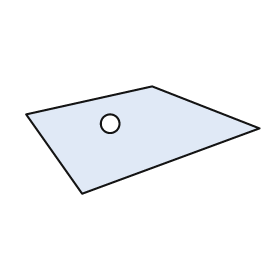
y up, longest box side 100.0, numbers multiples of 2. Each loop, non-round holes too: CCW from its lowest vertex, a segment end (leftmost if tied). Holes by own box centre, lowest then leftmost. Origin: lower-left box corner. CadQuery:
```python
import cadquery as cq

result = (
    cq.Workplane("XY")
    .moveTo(24.0, 0.0)
    .lineTo(100.0, 28.0)
    .lineTo(54.0, 46.0)
    .lineTo(0.0, 34.0)
    .close()
    .moveTo(36.0, 30.0)
    .circle(4.0)
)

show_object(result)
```